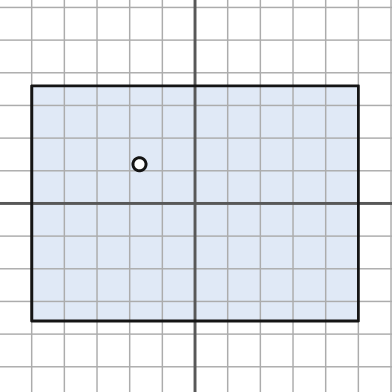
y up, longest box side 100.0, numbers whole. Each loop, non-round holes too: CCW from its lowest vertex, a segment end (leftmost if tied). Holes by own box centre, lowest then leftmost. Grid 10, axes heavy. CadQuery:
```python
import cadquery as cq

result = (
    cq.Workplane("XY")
    .moveTo(-50.0, -36.0)
    .lineTo(50.0, -36.0)
    .lineTo(50.0, 36.0)
    .lineTo(-50.0, 36.0)
    .close()
    .moveTo(-17.0, 12.0)
    .circle(2.0)
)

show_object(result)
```